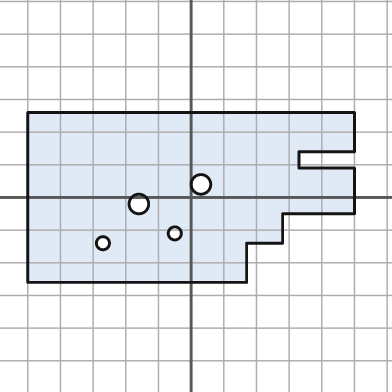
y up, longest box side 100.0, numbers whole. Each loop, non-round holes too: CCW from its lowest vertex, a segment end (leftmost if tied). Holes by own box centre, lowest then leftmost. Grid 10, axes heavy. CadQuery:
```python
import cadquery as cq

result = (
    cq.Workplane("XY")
    .moveTo(-50.0, -26.0)
    .lineTo(17.0, -26.0)
    .lineTo(17.0, -14.0)
    .lineTo(28.0, -14.0)
    .lineTo(28.0, -5.0)
    .lineTo(50.0, -5.0)
    .lineTo(50.0, 9.0)
    .lineTo(33.0, 9.0)
    .lineTo(33.0, 14.0)
    .lineTo(50.0, 14.0)
    .lineTo(50.0, 26.0)
    .lineTo(-50.0, 26.0)
    .close()
    .moveTo(-27.0, -14.0)
    .circle(2.0)
    .moveTo(-5.0, -11.0)
    .circle(2.0)
    .moveTo(-16.0, -2.0)
    .circle(3.0)
    .moveTo(3.0, 4.0)
    .circle(3.0)
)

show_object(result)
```